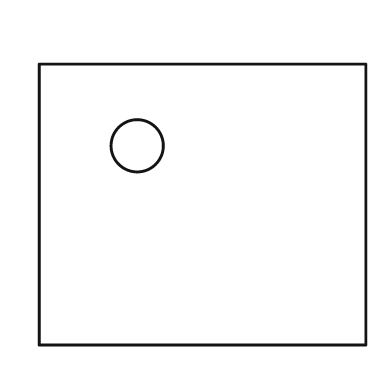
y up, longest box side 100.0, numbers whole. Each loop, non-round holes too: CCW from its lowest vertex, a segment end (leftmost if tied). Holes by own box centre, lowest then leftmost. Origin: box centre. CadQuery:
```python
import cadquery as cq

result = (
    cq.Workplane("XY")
    .moveTo(-50.0, -43.0)
    .lineTo(50.0, -43.0)
    .lineTo(50.0, 43.0)
    .lineTo(-50.0, 43.0)
    .close()
    .moveTo(-20.0, 18.0)
    .circle(8.0)
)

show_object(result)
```